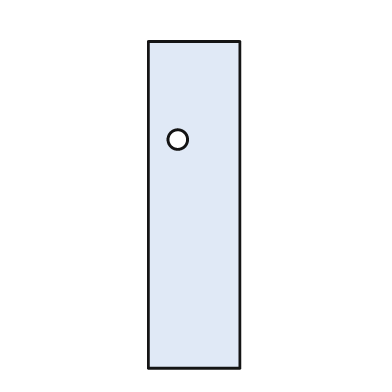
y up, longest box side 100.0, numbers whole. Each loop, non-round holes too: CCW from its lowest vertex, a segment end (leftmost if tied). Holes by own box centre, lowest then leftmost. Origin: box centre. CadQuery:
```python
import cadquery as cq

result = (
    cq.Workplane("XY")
    .moveTo(-14.0, -50.0)
    .lineTo(14.0, -50.0)
    .lineTo(14.0, 50.0)
    .lineTo(-14.0, 50.0)
    .close()
    .moveTo(-5.0, 20.0)
    .circle(3.0)
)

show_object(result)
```